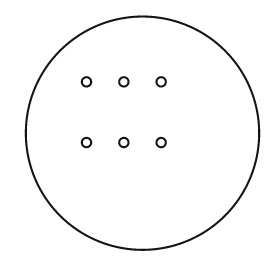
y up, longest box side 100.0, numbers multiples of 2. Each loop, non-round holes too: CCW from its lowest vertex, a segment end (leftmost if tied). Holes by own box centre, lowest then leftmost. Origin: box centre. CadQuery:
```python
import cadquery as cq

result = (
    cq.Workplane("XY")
    .moveTo(0.0, 0.0)
    .circle(50.0)
    .moveTo(-24.0, -4.0)
    .circle(2.0)
    .moveTo(-8.0, -4.0)
    .circle(2.0)
    .moveTo(8.0, -4.0)
    .circle(2.0)
    .moveTo(-24.0, 22.0)
    .circle(2.0)
    .moveTo(-8.0, 22.0)
    .circle(2.0)
    .moveTo(8.0, 22.0)
    .circle(2.0)
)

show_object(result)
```